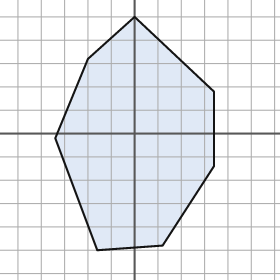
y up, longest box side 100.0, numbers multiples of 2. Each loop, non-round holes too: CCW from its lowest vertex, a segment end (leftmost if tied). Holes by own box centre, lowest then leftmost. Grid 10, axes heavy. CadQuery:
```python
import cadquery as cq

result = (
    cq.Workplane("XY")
    .moveTo(-16.0, -50.0)
    .lineTo(12.0, -48.0)
    .lineTo(34.0, -14.0)
    .lineTo(34.0, 18.0)
    .lineTo(0.0, 50.0)
    .lineTo(-20.0, 32.0)
    .lineTo(-34.0, -2.0)
    .close()
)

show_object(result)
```